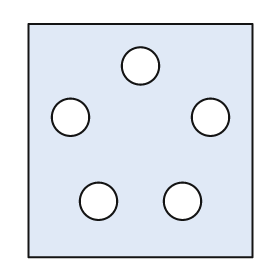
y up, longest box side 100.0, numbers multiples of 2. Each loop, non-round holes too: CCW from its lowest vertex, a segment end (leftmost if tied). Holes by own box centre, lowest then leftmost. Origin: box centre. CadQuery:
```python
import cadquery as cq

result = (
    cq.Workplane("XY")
    .moveTo(-48.0, -50.0)
    .lineTo(48.0, -50.0)
    .lineTo(48.0, 50.0)
    .lineTo(-48.0, 50.0)
    .close()
    .moveTo(-18.0, -26.0)
    .circle(8.0)
    .moveTo(18.0, -26.0)
    .circle(8.0)
    .moveTo(-30.0, 10.0)
    .circle(8.0)
    .moveTo(30.0, 10.0)
    .circle(8.0)
    .moveTo(0.0, 32.0)
    .circle(8.0)
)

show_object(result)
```